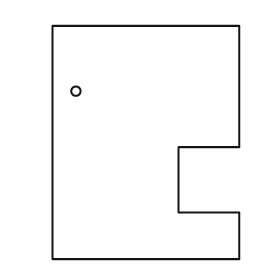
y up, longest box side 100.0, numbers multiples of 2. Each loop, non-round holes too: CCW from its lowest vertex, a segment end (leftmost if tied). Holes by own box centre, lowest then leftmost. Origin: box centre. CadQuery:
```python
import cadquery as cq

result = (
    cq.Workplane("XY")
    .moveTo(-40.0, -50.0)
    .lineTo(40.0, -50.0)
    .lineTo(40.0, -30.0)
    .lineTo(14.0, -30.0)
    .lineTo(14.0, -2.0)
    .lineTo(40.0, -2.0)
    .lineTo(40.0, 50.0)
    .lineTo(-40.0, 50.0)
    .close()
    .moveTo(-30.0, 22.0)
    .circle(2.0)
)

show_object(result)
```